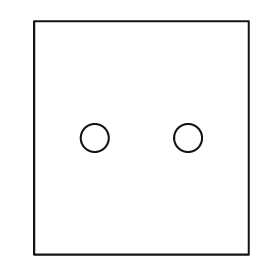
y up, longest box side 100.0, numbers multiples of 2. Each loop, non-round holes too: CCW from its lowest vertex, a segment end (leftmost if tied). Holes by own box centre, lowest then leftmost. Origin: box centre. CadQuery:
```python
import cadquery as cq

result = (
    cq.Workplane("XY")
    .moveTo(-46.0, -50.0)
    .lineTo(46.0, -50.0)
    .lineTo(46.0, 50.0)
    .lineTo(-46.0, 50.0)
    .close()
    .moveTo(-20.0, 0.0)
    .circle(6.0)
    .moveTo(20.0, 0.0)
    .circle(6.0)
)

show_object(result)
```